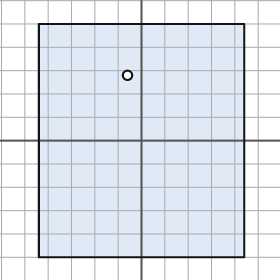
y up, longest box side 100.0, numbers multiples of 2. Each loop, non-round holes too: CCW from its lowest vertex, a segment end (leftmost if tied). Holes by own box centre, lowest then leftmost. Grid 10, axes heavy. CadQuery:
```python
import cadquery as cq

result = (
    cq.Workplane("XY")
    .moveTo(-44.0, -50.0)
    .lineTo(44.0, -50.0)
    .lineTo(44.0, 50.0)
    .lineTo(-44.0, 50.0)
    .close()
    .moveTo(-6.0, 28.0)
    .circle(2.0)
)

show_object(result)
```